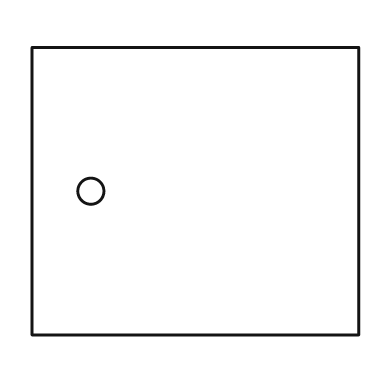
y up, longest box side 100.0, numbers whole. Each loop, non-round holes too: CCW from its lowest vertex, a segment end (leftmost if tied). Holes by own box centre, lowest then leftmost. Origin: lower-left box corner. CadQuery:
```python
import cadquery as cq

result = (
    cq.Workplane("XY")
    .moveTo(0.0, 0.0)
    .lineTo(100.0, 0.0)
    .lineTo(100.0, 88.0)
    .lineTo(0.0, 88.0)
    .close()
    .moveTo(18.0, 44.0)
    .circle(4.0)
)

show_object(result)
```